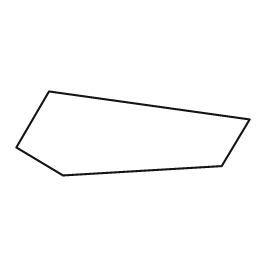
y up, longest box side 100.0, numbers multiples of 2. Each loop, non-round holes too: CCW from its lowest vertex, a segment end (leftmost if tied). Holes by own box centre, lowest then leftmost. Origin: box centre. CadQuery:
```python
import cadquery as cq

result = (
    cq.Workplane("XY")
    .moveTo(-30.0, -18.0)
    .lineTo(38.0, -14.0)
    .lineTo(50.0, 6.0)
    .lineTo(-36.0, 18.0)
    .lineTo(-50.0, -6.0)
    .close()
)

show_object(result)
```